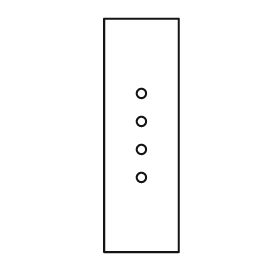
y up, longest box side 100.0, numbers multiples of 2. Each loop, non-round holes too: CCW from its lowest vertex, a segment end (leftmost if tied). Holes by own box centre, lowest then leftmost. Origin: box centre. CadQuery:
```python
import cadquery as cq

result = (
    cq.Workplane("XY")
    .moveTo(-16.0, -50.0)
    .lineTo(16.0, -50.0)
    .lineTo(16.0, 50.0)
    .lineTo(-16.0, 50.0)
    .close()
    .moveTo(0.0, -18.0)
    .circle(2.0)
    .moveTo(0.0, -6.0)
    .circle(2.0)
    .moveTo(0.0, 6.0)
    .circle(2.0)
    .moveTo(0.0, 18.0)
    .circle(2.0)
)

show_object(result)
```